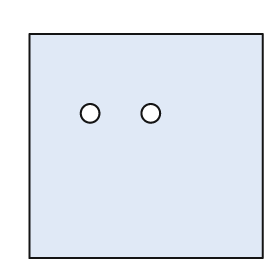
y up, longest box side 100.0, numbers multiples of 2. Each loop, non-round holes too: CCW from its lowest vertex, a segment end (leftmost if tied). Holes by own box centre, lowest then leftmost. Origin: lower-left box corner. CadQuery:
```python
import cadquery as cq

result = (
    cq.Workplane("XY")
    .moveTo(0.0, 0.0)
    .lineTo(100.0, 0.0)
    .lineTo(100.0, 96.0)
    .lineTo(0.0, 96.0)
    .close()
    .moveTo(26.0, 62.0)
    .circle(4.0)
    .moveTo(52.0, 62.0)
    .circle(4.0)
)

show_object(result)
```